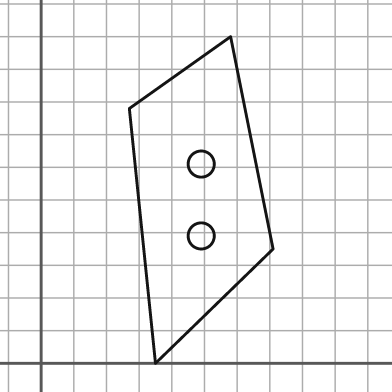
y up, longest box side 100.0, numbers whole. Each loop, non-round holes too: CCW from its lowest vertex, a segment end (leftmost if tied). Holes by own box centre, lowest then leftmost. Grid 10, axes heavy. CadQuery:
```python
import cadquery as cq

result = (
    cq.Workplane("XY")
    .moveTo(35.0, 0.0)
    .lineTo(71.0, 35.0)
    .lineTo(58.0, 100.0)
    .lineTo(27.0, 78.0)
    .close()
    .moveTo(49.0, 39.0)
    .circle(4.0)
    .moveTo(49.0, 61.0)
    .circle(4.0)
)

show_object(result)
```